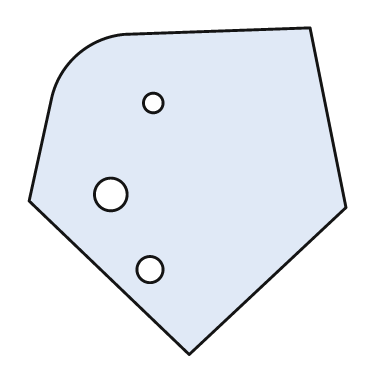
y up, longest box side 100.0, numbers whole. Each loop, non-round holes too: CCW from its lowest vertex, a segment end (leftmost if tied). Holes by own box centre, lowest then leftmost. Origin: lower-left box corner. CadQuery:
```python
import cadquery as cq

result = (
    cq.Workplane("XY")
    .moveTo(49.0, 0.0)
    .lineTo(97.0, 45.0)
    .lineTo(86.0, 100.0)
    .lineTo(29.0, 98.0)
    .threePointArc((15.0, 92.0), (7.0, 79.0))
    .lineTo(0.0, 47.0)
    .close()
    .moveTo(37.0, 26.0)
    .circle(4.0)
    .moveTo(25.0, 49.0)
    .circle(5.0)
    .moveTo(38.0, 77.0)
    .circle(3.0)
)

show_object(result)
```